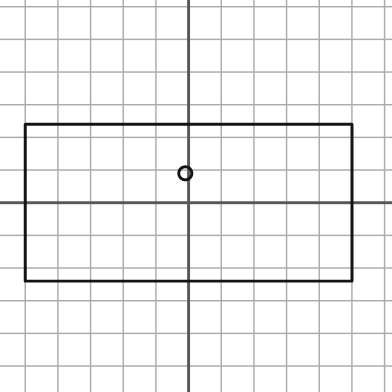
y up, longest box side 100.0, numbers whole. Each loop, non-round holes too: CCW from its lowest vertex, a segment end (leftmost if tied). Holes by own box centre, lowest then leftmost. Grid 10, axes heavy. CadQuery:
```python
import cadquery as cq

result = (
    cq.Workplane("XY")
    .moveTo(-50.0, -24.0)
    .lineTo(50.0, -24.0)
    .lineTo(50.0, 24.0)
    .lineTo(-50.0, 24.0)
    .close()
    .moveTo(-1.0, 9.0)
    .circle(2.0)
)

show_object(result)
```